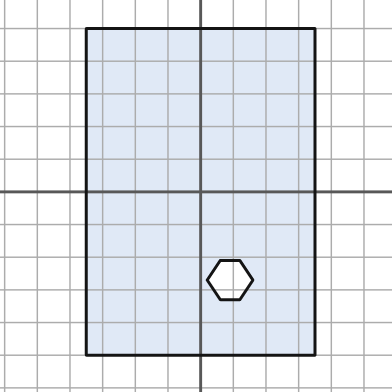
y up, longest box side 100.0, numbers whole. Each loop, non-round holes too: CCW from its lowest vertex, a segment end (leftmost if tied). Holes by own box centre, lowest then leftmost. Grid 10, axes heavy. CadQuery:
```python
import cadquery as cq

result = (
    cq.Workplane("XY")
    .moveTo(-35.0, -50.0)
    .lineTo(35.0, -50.0)
    .lineTo(35.0, 50.0)
    .lineTo(-35.0, 50.0)
    .close()
    .moveTo(6.0, -33.0)
    .lineTo(12.0, -33.0)
    .lineTo(16.0, -27.0)
    .lineTo(12.0, -21.0)
    .lineTo(6.0, -21.0)
    .lineTo(2.0, -27.0)
    .close()
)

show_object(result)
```